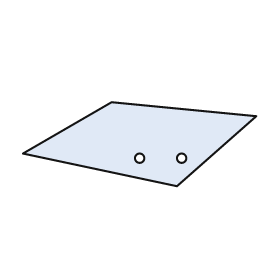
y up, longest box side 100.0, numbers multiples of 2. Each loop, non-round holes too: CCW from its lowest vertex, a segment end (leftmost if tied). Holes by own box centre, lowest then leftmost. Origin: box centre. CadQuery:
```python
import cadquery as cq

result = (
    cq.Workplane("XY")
    .moveTo(16.0, -18.0)
    .lineTo(50.0, 12.0)
    .lineTo(-12.0, 18.0)
    .lineTo(-50.0, -4.0)
    .close()
    .moveTo(0.0, -6.0)
    .circle(2.0)
    .moveTo(18.0, -6.0)
    .circle(2.0)
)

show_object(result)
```